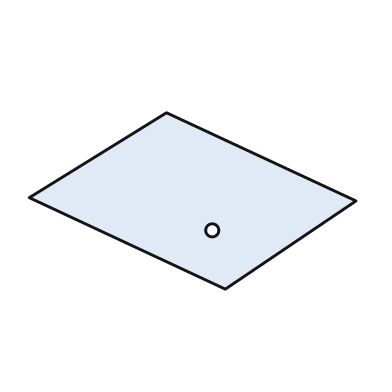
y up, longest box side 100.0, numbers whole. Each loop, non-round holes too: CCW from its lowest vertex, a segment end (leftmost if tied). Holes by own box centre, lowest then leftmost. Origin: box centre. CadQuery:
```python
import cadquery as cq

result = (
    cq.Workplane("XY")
    .moveTo(10.0, -27.0)
    .lineTo(50.0, 0.0)
    .lineTo(-8.0, 27.0)
    .lineTo(-50.0, 1.0)
    .close()
    .moveTo(6.0, -9.0)
    .circle(2.0)
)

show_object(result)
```